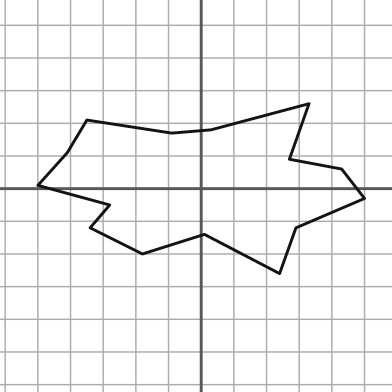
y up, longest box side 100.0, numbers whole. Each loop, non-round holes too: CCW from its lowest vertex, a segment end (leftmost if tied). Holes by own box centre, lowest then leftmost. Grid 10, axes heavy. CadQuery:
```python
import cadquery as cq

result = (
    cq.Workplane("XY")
    .moveTo(24.0, -26.0)
    .lineTo(29.0, -12.0)
    .lineTo(50.0, -3.0)
    .lineTo(43.0, 6.0)
    .lineTo(27.0, 9.0)
    .lineTo(33.0, 26.0)
    .lineTo(3.0, 18.0)
    .lineTo(-9.0, 17.0)
    .lineTo(-35.0, 21.0)
    .lineTo(-41.0, 11.0)
    .lineTo(-50.0, 1.0)
    .lineTo(-28.0, -5.0)
    .lineTo(-34.0, -12.0)
    .lineTo(-18.0, -20.0)
    .lineTo(1.0, -14.0)
    .close()
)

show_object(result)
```